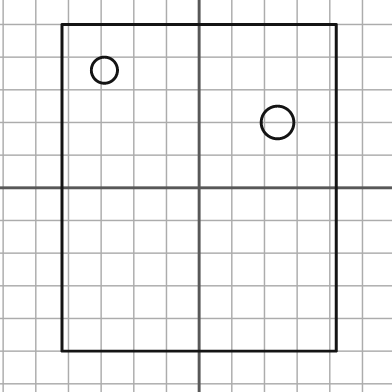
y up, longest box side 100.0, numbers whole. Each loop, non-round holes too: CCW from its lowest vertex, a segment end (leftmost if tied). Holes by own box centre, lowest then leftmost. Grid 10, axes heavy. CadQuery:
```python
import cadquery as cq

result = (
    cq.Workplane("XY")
    .moveTo(-42.0, -50.0)
    .lineTo(42.0, -50.0)
    .lineTo(42.0, 50.0)
    .lineTo(-42.0, 50.0)
    .close()
    .moveTo(24.0, 20.0)
    .circle(5.0)
    .moveTo(-29.0, 36.0)
    .circle(4.0)
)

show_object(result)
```